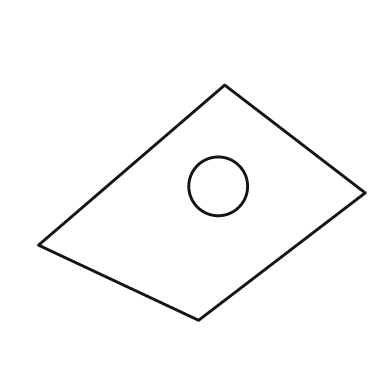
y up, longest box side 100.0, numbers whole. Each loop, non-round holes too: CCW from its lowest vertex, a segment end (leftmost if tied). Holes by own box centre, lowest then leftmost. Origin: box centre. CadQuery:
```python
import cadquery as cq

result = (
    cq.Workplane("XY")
    .moveTo(-1.0, -36.0)
    .lineTo(50.0, 3.0)
    .lineTo(7.0, 36.0)
    .lineTo(-50.0, -13.0)
    .close()
    .moveTo(5.0, 5.0)
    .circle(9.0)
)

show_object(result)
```